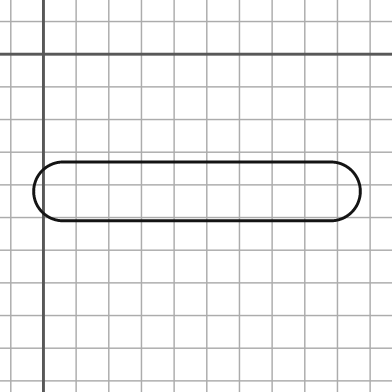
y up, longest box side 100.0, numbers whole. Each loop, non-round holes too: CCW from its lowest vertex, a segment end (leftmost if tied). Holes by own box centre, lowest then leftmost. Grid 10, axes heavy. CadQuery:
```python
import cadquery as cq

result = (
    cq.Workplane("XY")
    .moveTo(6.0, -51.0)
    .lineTo(88.0, -51.0)
    .threePointArc((97.0, -42.0), (88.0, -33.0))
    .lineTo(6.0, -33.0)
    .threePointArc((-3.0, -42.0), (6.0, -51.0))
    .close()
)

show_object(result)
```